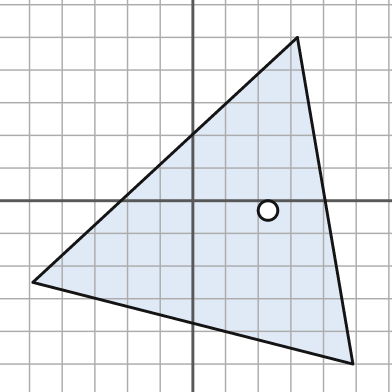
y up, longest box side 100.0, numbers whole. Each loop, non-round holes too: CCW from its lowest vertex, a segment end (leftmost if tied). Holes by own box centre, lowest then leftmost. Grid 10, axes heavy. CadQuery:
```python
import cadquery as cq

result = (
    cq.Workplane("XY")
    .moveTo(49.0, -50.0)
    .lineTo(32.0, 50.0)
    .lineTo(-49.0, -25.0)
    .close()
    .moveTo(23.0, -3.0)
    .circle(3.0)
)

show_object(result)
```